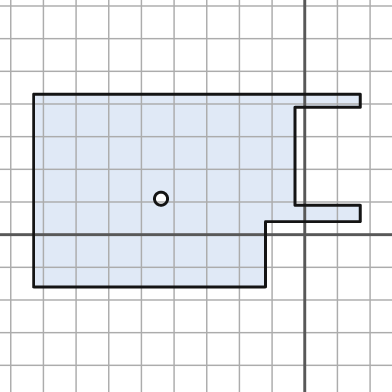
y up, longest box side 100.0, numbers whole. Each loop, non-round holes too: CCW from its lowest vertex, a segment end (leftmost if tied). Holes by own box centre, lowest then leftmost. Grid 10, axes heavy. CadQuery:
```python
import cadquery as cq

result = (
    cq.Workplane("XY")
    .moveTo(-83.0, -16.0)
    .lineTo(-12.0, -16.0)
    .lineTo(-12.0, 4.0)
    .lineTo(17.0, 4.0)
    .lineTo(17.0, 9.0)
    .lineTo(-3.0, 9.0)
    .lineTo(-3.0, 39.0)
    .lineTo(17.0, 39.0)
    .lineTo(17.0, 43.0)
    .lineTo(-83.0, 43.0)
    .close()
    .moveTo(-44.0, 11.0)
    .circle(2.0)
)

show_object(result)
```